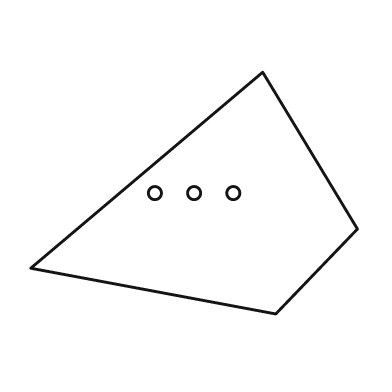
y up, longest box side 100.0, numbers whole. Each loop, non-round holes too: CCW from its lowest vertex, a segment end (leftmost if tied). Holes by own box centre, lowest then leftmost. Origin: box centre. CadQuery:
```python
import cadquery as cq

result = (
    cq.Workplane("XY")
    .moveTo(25.0, -37.0)
    .lineTo(50.0, -11.0)
    .lineTo(21.0, 37.0)
    .lineTo(-50.0, -23.0)
    .close()
    .moveTo(-12.0, 0.0)
    .circle(2.0)
    .moveTo(0.0, 0.0)
    .circle(2.0)
    .moveTo(12.0, 0.0)
    .circle(2.0)
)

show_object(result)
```